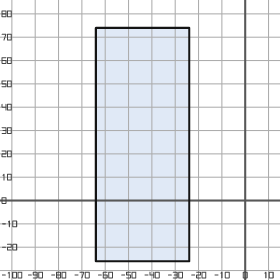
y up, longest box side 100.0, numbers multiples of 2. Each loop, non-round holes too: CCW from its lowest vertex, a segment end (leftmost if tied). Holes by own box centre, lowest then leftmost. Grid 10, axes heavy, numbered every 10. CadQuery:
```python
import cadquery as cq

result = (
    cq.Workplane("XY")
    .moveTo(-64.0, -26.0)
    .lineTo(-24.0, -26.0)
    .lineTo(-24.0, 74.0)
    .lineTo(-64.0, 74.0)
    .close()
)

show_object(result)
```